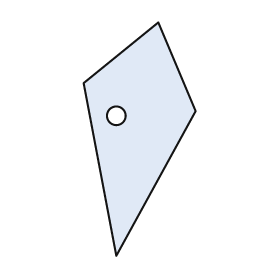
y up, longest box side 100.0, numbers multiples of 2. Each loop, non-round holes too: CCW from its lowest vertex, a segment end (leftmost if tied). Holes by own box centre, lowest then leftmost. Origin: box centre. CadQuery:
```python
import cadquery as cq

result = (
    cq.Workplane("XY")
    .moveTo(-10.0, -50.0)
    .lineTo(24.0, 12.0)
    .lineTo(8.0, 50.0)
    .lineTo(-24.0, 24.0)
    .close()
    .moveTo(-10.0, 10.0)
    .circle(4.0)
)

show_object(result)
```